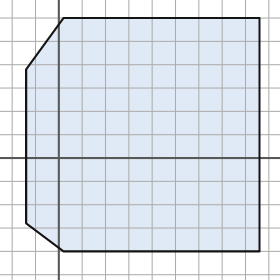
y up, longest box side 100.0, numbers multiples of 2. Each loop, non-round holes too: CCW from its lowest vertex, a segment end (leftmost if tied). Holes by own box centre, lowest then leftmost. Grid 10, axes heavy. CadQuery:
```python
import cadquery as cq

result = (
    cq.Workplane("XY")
    .moveTo(2.0, -40.0)
    .lineTo(86.0, -40.0)
    .lineTo(86.0, 60.0)
    .lineTo(2.0, 60.0)
    .lineTo(-14.0, 38.0)
    .lineTo(-14.0, -28.0)
    .close()
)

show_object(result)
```